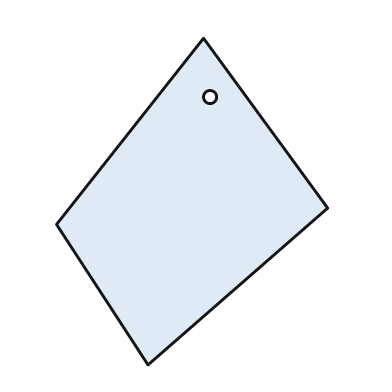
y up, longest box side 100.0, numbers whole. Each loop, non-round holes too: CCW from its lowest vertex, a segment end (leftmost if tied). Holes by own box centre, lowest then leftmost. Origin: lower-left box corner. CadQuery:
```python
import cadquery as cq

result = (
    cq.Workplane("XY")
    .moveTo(28.0, 0.0)
    .lineTo(83.0, 48.0)
    .lineTo(45.0, 100.0)
    .lineTo(0.0, 43.0)
    .close()
    .moveTo(47.0, 82.0)
    .circle(2.0)
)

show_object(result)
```